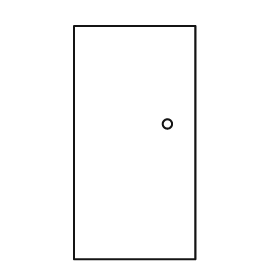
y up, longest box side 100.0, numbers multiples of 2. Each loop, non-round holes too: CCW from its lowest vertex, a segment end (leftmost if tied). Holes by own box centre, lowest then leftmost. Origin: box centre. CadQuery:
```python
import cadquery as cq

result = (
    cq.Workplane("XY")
    .moveTo(-26.0, -50.0)
    .lineTo(26.0, -50.0)
    .lineTo(26.0, 50.0)
    .lineTo(-26.0, 50.0)
    .close()
    .moveTo(14.0, 8.0)
    .circle(2.0)
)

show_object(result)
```